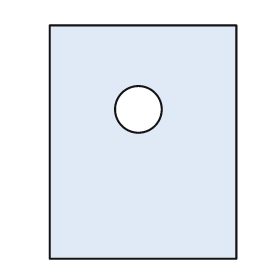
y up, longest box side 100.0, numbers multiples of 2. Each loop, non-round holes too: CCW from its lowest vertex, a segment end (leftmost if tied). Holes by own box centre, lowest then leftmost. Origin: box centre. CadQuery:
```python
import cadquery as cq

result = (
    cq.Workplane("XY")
    .moveTo(-40.0, -50.0)
    .lineTo(40.0, -50.0)
    .lineTo(40.0, 50.0)
    .lineTo(-40.0, 50.0)
    .close()
    .moveTo(-2.0, 14.0)
    .circle(10.0)
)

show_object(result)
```